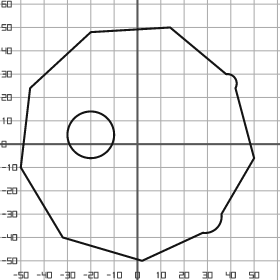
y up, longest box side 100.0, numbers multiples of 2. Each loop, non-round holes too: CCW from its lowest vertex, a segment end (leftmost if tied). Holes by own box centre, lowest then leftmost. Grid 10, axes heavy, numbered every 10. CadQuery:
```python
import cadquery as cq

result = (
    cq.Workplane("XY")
    .moveTo(2.0, -50.0)
    .lineTo(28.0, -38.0)
    .threePointArc((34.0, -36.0), (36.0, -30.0))
    .lineTo(50.0, -6.0)
    .lineTo(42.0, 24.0)
    .threePointArc((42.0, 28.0), (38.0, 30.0))
    .lineTo(14.0, 50.0)
    .lineTo(-20.0, 48.0)
    .lineTo(-46.0, 24.0)
    .lineTo(-50.0, -10.0)
    .lineTo(-32.0, -40.0)
    .close()
    .moveTo(-20.0, 4.0)
    .circle(10.0)
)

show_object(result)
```